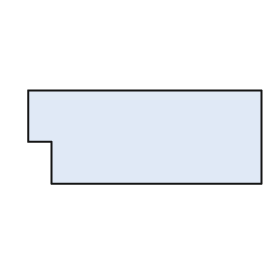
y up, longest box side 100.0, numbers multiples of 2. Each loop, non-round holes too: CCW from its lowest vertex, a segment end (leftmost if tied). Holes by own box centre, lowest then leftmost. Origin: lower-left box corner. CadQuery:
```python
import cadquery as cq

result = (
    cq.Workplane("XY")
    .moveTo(10.0, 0.0)
    .lineTo(100.0, 0.0)
    .lineTo(100.0, 40.0)
    .lineTo(0.0, 40.0)
    .lineTo(0.0, 18.0)
    .lineTo(10.0, 18.0)
    .close()
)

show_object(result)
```